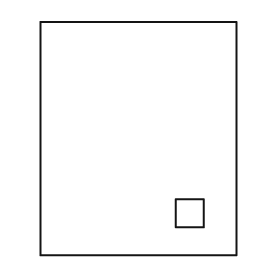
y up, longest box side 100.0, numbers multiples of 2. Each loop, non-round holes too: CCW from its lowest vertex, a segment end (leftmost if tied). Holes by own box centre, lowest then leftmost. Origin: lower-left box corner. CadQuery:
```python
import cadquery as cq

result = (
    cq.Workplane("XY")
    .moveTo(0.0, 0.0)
    .lineTo(84.0, 0.0)
    .lineTo(84.0, 100.0)
    .lineTo(0.0, 100.0)
    .close()
    .moveTo(58.0, 12.0)
    .lineTo(70.0, 12.0)
    .lineTo(70.0, 24.0)
    .lineTo(58.0, 24.0)
    .close()
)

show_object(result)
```